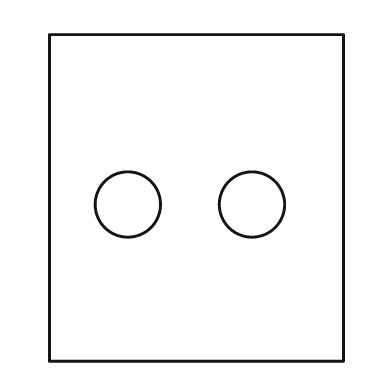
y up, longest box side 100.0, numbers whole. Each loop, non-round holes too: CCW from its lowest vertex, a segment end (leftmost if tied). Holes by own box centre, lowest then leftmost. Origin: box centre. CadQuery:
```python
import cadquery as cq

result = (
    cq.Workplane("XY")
    .moveTo(-45.0, -50.0)
    .lineTo(45.0, -50.0)
    .lineTo(45.0, 50.0)
    .lineTo(-45.0, 50.0)
    .close()
    .moveTo(-21.0, -2.0)
    .circle(10.0)
    .moveTo(17.0, -2.0)
    .circle(10.0)
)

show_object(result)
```